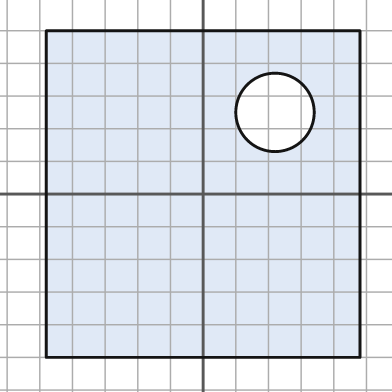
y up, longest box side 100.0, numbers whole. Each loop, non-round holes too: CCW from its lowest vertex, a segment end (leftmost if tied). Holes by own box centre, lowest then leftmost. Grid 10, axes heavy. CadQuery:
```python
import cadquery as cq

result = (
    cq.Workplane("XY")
    .moveTo(-48.0, -50.0)
    .lineTo(48.0, -50.0)
    .lineTo(48.0, 50.0)
    .lineTo(-48.0, 50.0)
    .close()
    .moveTo(22.0, 25.0)
    .circle(12.0)
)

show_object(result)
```